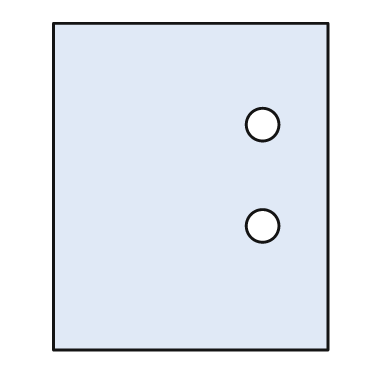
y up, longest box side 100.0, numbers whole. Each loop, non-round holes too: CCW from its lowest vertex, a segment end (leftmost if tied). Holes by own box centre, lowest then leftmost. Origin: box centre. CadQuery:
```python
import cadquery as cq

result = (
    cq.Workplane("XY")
    .moveTo(-42.0, -50.0)
    .lineTo(42.0, -50.0)
    .lineTo(42.0, 50.0)
    .lineTo(-42.0, 50.0)
    .close()
    .moveTo(22.0, -12.0)
    .circle(5.0)
    .moveTo(22.0, 19.0)
    .circle(5.0)
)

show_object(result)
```